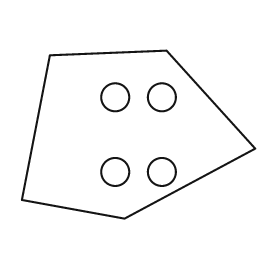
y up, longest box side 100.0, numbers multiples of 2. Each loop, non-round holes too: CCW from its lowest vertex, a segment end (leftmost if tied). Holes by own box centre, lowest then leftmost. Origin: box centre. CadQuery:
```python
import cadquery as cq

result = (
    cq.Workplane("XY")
    .moveTo(-6.0, -36.0)
    .lineTo(50.0, -6.0)
    .lineTo(12.0, 36.0)
    .lineTo(-38.0, 34.0)
    .lineTo(-50.0, -28.0)
    .close()
    .moveTo(-10.0, -16.0)
    .circle(6.0)
    .moveTo(10.0, -16.0)
    .circle(6.0)
    .moveTo(-10.0, 16.0)
    .circle(6.0)
    .moveTo(10.0, 16.0)
    .circle(6.0)
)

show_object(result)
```